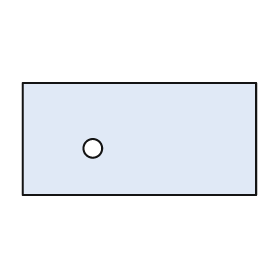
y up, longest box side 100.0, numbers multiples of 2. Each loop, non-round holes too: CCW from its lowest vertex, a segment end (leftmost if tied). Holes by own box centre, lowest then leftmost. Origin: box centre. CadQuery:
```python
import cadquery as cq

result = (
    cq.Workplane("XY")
    .moveTo(-50.0, -24.0)
    .lineTo(50.0, -24.0)
    .lineTo(50.0, 24.0)
    .lineTo(-50.0, 24.0)
    .close()
    .moveTo(-20.0, -4.0)
    .circle(4.0)
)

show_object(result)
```